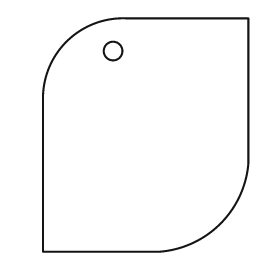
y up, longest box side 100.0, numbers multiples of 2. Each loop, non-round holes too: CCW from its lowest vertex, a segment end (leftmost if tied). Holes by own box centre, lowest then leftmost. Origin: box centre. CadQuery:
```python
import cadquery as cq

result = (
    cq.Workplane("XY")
    .moveTo(-44.0, -50.0)
    .lineTo(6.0, -50.0)
    .threePointArc((32.0, -38.0), (44.0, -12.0))
    .lineTo(44.0, 50.0)
    .lineTo(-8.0, 50.0)
    .threePointArc((-34.0, 40.0), (-44.0, 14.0))
    .close()
    .moveTo(-14.0, 36.0)
    .circle(4.0)
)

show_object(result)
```